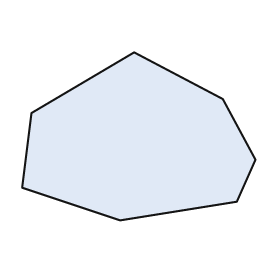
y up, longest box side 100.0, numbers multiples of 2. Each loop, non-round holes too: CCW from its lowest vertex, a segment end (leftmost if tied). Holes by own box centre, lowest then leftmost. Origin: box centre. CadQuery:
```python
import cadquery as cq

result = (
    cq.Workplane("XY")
    .moveTo(-8.0, -36.0)
    .lineTo(42.0, -28.0)
    .lineTo(50.0, -10.0)
    .lineTo(36.0, 16.0)
    .lineTo(-2.0, 36.0)
    .lineTo(-46.0, 10.0)
    .lineTo(-50.0, -22.0)
    .close()
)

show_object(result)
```